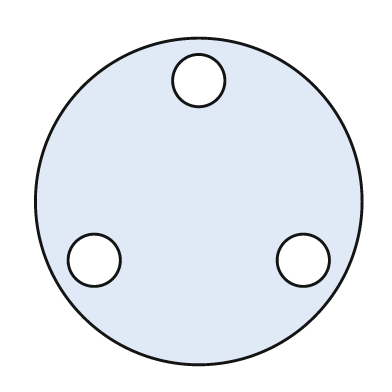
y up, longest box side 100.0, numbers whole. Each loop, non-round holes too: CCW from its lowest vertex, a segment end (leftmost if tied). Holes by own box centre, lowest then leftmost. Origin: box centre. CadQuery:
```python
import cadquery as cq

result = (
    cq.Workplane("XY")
    .moveTo(0.0, 0.0)
    .circle(50.0)
    .moveTo(-32.0, -18.0)
    .circle(8.0)
    .moveTo(32.0, -18.0)
    .circle(8.0)
    .moveTo(0.0, 37.0)
    .circle(8.0)
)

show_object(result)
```